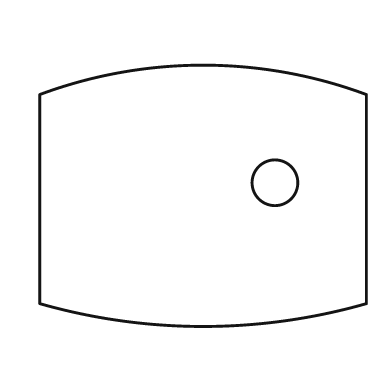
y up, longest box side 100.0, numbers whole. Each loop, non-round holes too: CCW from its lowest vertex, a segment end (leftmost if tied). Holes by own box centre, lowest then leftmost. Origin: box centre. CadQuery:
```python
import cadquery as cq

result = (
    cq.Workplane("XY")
    .moveTo(-50.0, -33.0)
    .threePointArc((0.0, -40.0), (50.0, -33.0))
    .lineTo(50.0, 31.0)
    .threePointArc((0.0, 40.0), (-50.0, 31.0))
    .close()
    .moveTo(22.0, 4.0)
    .circle(7.0)
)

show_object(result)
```